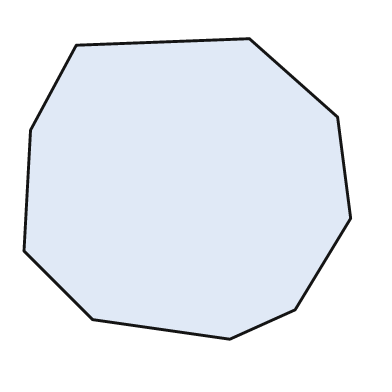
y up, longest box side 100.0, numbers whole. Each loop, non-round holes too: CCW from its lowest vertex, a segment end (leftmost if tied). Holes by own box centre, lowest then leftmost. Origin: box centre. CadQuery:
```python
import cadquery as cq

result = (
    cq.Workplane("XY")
    .moveTo(13.0, -46.0)
    .lineTo(33.0, -37.0)
    .lineTo(50.0, -9.0)
    .lineTo(46.0, 22.0)
    .lineTo(19.0, 46.0)
    .lineTo(-34.0, 44.0)
    .lineTo(-48.0, 18.0)
    .lineTo(-50.0, -19.0)
    .lineTo(-29.0, -40.0)
    .close()
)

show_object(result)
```